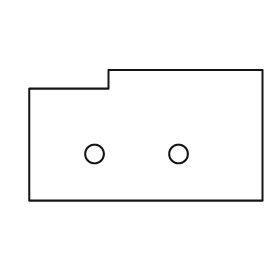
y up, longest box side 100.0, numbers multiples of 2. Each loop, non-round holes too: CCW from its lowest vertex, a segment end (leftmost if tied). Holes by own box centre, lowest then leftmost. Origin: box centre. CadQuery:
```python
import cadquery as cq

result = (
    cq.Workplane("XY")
    .moveTo(-50.0, -28.0)
    .lineTo(50.0, -28.0)
    .lineTo(50.0, 28.0)
    .lineTo(-16.0, 28.0)
    .lineTo(-16.0, 20.0)
    .lineTo(-50.0, 20.0)
    .close()
    .moveTo(-22.0, -8.0)
    .circle(4.0)
    .moveTo(14.0, -8.0)
    .circle(4.0)
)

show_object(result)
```